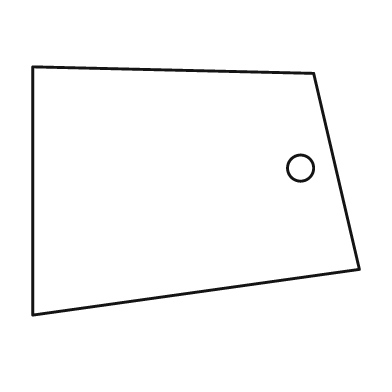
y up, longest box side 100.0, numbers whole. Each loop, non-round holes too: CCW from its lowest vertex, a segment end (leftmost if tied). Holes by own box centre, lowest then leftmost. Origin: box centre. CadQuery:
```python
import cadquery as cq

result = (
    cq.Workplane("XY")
    .moveTo(-50.0, -38.0)
    .lineTo(50.0, -24.0)
    .lineTo(36.0, 36.0)
    .lineTo(-50.0, 38.0)
    .close()
    .moveTo(32.0, 7.0)
    .circle(4.0)
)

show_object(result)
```